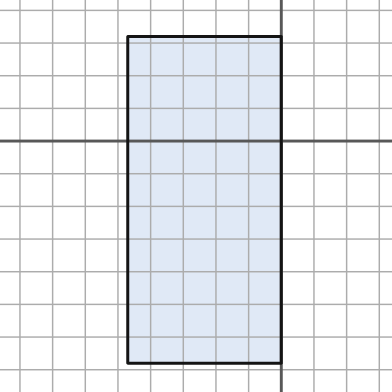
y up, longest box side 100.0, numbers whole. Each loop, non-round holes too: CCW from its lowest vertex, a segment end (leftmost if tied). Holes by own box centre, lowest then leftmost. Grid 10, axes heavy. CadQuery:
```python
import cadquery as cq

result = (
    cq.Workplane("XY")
    .moveTo(-47.0, -68.0)
    .lineTo(0.0, -68.0)
    .lineTo(0.0, 32.0)
    .lineTo(-47.0, 32.0)
    .close()
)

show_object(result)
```